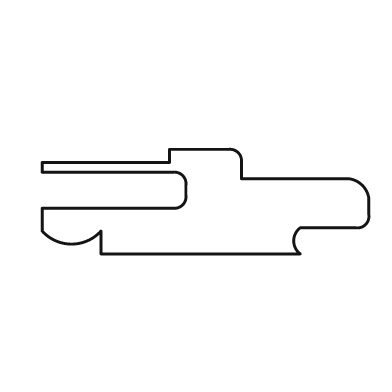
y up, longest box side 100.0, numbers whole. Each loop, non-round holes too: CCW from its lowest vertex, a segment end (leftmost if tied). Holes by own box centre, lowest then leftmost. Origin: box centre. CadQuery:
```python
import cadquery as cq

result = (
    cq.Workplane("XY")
    .moveTo(-32.0, -16.0)
    .lineTo(29.0, -16.0)
    .threePointArc((27.0, -12.0), (29.0, -8.0))
    .lineTo(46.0, -8.0)
    .threePointArc((49.0, -7.0), (50.0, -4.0))
    .lineTo(50.0, 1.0)
    .threePointArc((48.0, 5.0), (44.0, 7.0))
    .lineTo(11.0, 7.0)
    .lineTo(11.0, 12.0)
    .threePointArc((10.0, 15.0), (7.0, 16.0))
    .lineTo(-11.0, 16.0)
    .lineTo(-11.0, 12.0)
    .lineTo(-50.0, 12.0)
    .lineTo(-50.0, 9.0)
    .lineTo(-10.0, 9.0)
    .threePointArc((-7.0, 8.0), (-6.0, 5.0))
    .lineTo(-6.0, 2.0)
    .threePointArc((-7.0, -1.0), (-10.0, -2.0))
    .lineTo(-50.0, -2.0)
    .lineTo(-50.0, -9.0)
    .threePointArc((-41.0, -13.0), (-32.0, -9.0))
    .close()
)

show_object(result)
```